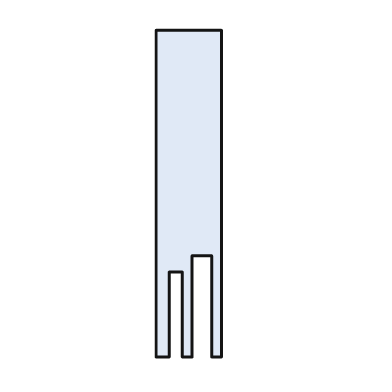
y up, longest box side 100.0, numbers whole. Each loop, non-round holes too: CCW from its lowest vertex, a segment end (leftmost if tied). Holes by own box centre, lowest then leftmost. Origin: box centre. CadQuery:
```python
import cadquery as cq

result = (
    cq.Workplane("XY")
    .moveTo(-10.0, -50.0)
    .lineTo(-6.0, -50.0)
    .lineTo(-6.0, -24.0)
    .lineTo(-2.0, -24.0)
    .lineTo(-2.0, -50.0)
    .lineTo(1.0, -50.0)
    .lineTo(1.0, -19.0)
    .lineTo(7.0, -19.0)
    .lineTo(7.0, -50.0)
    .lineTo(10.0, -50.0)
    .lineTo(10.0, 50.0)
    .lineTo(-10.0, 50.0)
    .close()
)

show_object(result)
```